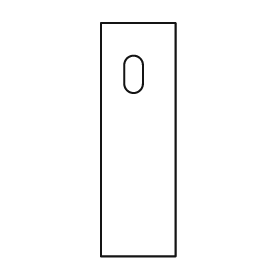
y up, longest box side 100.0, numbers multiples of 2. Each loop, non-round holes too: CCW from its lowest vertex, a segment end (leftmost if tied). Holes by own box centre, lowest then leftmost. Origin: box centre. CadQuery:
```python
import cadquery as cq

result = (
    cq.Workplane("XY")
    .moveTo(-16.0, -50.0)
    .lineTo(16.0, -50.0)
    .lineTo(16.0, 50.0)
    .lineTo(-16.0, 50.0)
    .close()
    .moveTo(-6.0, 24.0)
    .threePointArc((-2.0, 20.0), (2.0, 24.0))
    .lineTo(2.0, 32.0)
    .threePointArc((-2.0, 36.0), (-6.0, 32.0))
    .close()
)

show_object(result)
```